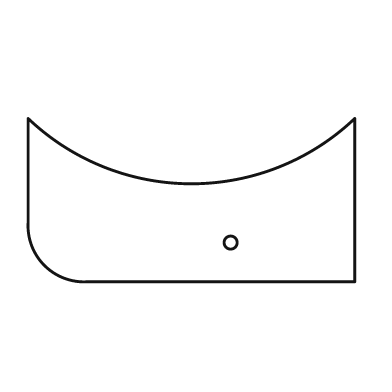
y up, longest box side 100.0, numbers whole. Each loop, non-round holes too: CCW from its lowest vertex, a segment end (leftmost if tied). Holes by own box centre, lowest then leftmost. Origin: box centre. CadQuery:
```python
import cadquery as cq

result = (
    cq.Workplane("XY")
    .moveTo(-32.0, -25.0)
    .lineTo(50.0, -25.0)
    .lineTo(50.0, 25.0)
    .threePointArc((0.0, 5.0), (-50.0, 25.0))
    .lineTo(-50.0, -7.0)
    .threePointArc((-45.0, -20.0), (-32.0, -25.0))
    .close()
    .moveTo(12.0, -13.0)
    .circle(2.0)
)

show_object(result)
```